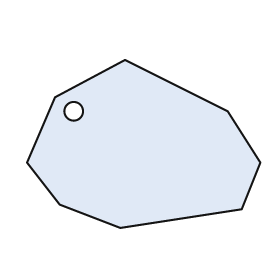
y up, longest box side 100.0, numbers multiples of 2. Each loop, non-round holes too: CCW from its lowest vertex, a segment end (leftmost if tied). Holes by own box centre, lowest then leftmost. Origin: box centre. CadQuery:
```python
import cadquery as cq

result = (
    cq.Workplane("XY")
    .moveTo(-10.0, -36.0)
    .lineTo(42.0, -28.0)
    .lineTo(50.0, -8.0)
    .lineTo(36.0, 14.0)
    .lineTo(-8.0, 36.0)
    .lineTo(-38.0, 20.0)
    .lineTo(-50.0, -8.0)
    .lineTo(-36.0, -26.0)
    .close()
    .moveTo(-30.0, 14.0)
    .circle(4.0)
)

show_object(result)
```